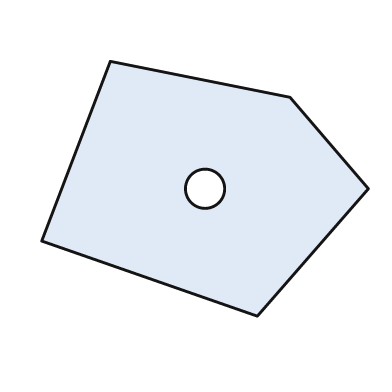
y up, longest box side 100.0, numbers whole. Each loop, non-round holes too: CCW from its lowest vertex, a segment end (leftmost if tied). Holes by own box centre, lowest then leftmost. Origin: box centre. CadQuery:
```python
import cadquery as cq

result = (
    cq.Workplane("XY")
    .moveTo(16.0, -39.0)
    .lineTo(50.0, 0.0)
    .lineTo(26.0, 28.0)
    .lineTo(-29.0, 39.0)
    .lineTo(-50.0, -16.0)
    .close()
    .moveTo(0.0, 0.0)
    .circle(6.0)
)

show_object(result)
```